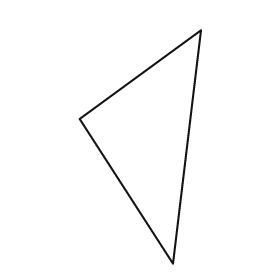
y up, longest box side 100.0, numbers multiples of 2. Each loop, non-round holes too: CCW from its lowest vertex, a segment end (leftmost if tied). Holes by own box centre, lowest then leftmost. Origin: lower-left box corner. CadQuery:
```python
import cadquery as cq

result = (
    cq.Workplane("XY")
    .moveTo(40.0, 0.0)
    .lineTo(52.0, 100.0)
    .lineTo(0.0, 62.0)
    .close()
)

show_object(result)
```